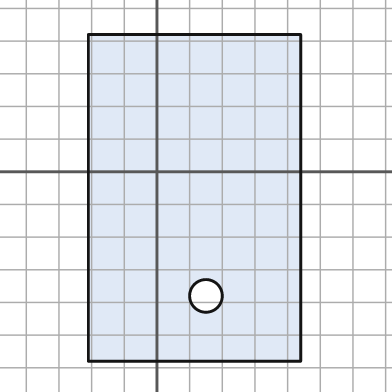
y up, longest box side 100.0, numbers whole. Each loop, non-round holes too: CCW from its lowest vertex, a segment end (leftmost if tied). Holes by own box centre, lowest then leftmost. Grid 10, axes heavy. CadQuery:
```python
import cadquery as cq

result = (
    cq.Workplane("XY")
    .moveTo(-21.0, -58.0)
    .lineTo(44.0, -58.0)
    .lineTo(44.0, 42.0)
    .lineTo(-21.0, 42.0)
    .close()
    .moveTo(15.0, -38.0)
    .circle(5.0)
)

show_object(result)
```